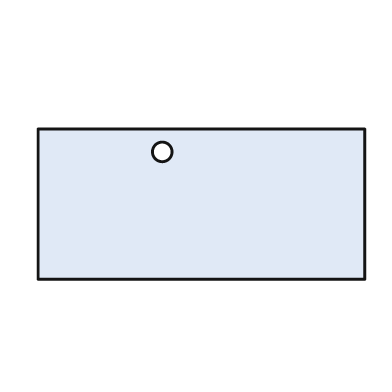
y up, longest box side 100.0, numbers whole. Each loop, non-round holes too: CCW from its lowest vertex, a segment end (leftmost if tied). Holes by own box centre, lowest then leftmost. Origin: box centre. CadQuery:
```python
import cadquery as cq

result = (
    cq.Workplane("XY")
    .moveTo(-50.0, -23.0)
    .lineTo(50.0, -23.0)
    .lineTo(50.0, 23.0)
    .lineTo(-50.0, 23.0)
    .close()
    .moveTo(-12.0, 16.0)
    .circle(3.0)
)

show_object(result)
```